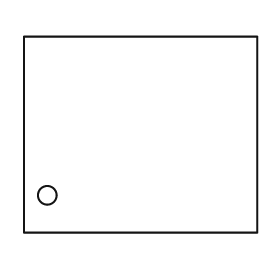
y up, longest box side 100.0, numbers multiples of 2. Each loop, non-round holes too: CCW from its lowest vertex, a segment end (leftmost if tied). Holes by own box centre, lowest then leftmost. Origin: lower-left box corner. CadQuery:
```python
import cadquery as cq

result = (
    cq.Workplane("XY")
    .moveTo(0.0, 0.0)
    .lineTo(100.0, 0.0)
    .lineTo(100.0, 84.0)
    .lineTo(0.0, 84.0)
    .close()
    .moveTo(10.0, 16.0)
    .circle(4.0)
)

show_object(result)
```